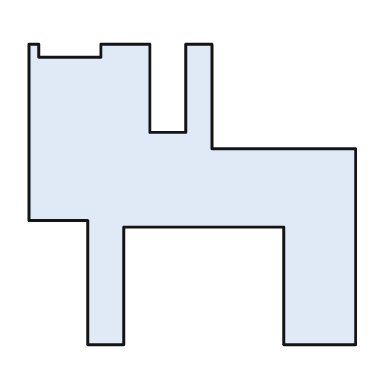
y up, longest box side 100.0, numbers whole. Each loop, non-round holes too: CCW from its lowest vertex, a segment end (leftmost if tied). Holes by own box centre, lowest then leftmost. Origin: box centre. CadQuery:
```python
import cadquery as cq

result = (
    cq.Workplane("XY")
    .moveTo(-32.0, -46.0)
    .lineTo(-21.0, -46.0)
    .lineTo(-21.0, -10.0)
    .lineTo(28.0, -10.0)
    .lineTo(28.0, -46.0)
    .lineTo(50.0, -46.0)
    .lineTo(50.0, 14.0)
    .lineTo(6.0, 14.0)
    .lineTo(6.0, 46.0)
    .lineTo(-2.0, 46.0)
    .lineTo(-2.0, 19.0)
    .lineTo(-13.0, 19.0)
    .lineTo(-13.0, 46.0)
    .lineTo(-28.0, 46.0)
    .lineTo(-28.0, 42.0)
    .lineTo(-47.0, 42.0)
    .lineTo(-47.0, 46.0)
    .lineTo(-50.0, 46.0)
    .lineTo(-50.0, -8.0)
    .lineTo(-32.0, -8.0)
    .close()
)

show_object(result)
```